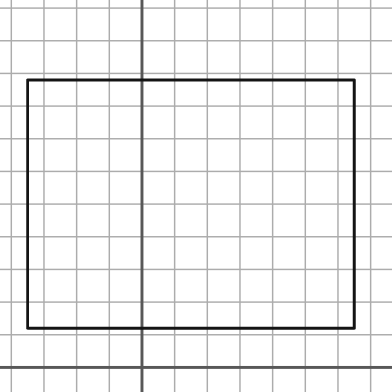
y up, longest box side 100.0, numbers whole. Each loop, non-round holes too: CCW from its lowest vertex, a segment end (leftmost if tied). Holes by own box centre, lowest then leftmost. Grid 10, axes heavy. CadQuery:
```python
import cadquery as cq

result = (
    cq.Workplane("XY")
    .moveTo(-35.0, 12.0)
    .lineTo(65.0, 12.0)
    .lineTo(65.0, 88.0)
    .lineTo(-35.0, 88.0)
    .close()
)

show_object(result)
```